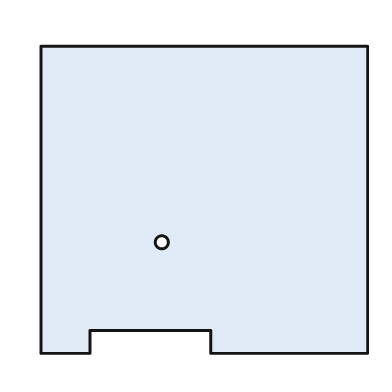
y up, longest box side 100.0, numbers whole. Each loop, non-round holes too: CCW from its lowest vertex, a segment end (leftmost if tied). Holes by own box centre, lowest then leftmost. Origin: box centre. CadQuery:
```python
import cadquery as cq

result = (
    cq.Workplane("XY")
    .moveTo(-50.0, -47.0)
    .lineTo(-35.0, -47.0)
    .lineTo(-35.0, -40.0)
    .lineTo(2.0, -40.0)
    .lineTo(2.0, -47.0)
    .lineTo(50.0, -47.0)
    .lineTo(50.0, 47.0)
    .lineTo(-50.0, 47.0)
    .close()
    .moveTo(-13.0, -13.0)
    .circle(2.0)
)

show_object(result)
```